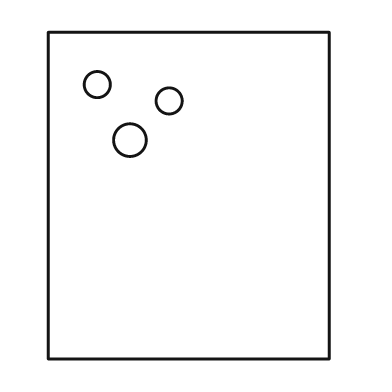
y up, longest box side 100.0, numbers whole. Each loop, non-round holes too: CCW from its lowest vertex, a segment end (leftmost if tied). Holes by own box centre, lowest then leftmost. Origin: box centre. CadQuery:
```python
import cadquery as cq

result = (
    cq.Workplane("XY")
    .moveTo(-43.0, -50.0)
    .lineTo(43.0, -50.0)
    .lineTo(43.0, 50.0)
    .lineTo(-43.0, 50.0)
    .close()
    .moveTo(-18.0, 17.0)
    .circle(5.0)
    .moveTo(-6.0, 29.0)
    .circle(4.0)
    .moveTo(-28.0, 34.0)
    .circle(4.0)
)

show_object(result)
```